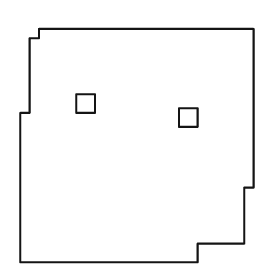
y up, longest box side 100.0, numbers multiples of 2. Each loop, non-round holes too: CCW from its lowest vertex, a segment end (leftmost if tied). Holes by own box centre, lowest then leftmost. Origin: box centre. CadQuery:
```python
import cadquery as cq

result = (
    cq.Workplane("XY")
    .moveTo(-50.0, -50.0)
    .lineTo(26.0, -50.0)
    .lineTo(26.0, -42.0)
    .lineTo(46.0, -42.0)
    .lineTo(46.0, -18.0)
    .lineTo(50.0, -18.0)
    .lineTo(50.0, 50.0)
    .lineTo(-42.0, 50.0)
    .lineTo(-42.0, 46.0)
    .lineTo(-46.0, 46.0)
    .lineTo(-46.0, 14.0)
    .lineTo(-50.0, 14.0)
    .close()
    .moveTo(18.0, 8.0)
    .lineTo(26.0, 8.0)
    .lineTo(26.0, 16.0)
    .lineTo(18.0, 16.0)
    .close()
    .moveTo(-26.0, 14.0)
    .lineTo(-18.0, 14.0)
    .lineTo(-18.0, 22.0)
    .lineTo(-26.0, 22.0)
    .close()
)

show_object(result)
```